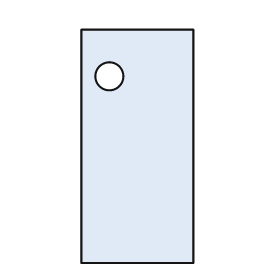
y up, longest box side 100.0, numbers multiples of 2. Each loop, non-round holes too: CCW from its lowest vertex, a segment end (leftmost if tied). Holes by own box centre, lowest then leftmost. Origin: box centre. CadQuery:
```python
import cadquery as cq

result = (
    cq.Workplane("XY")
    .moveTo(-24.0, -50.0)
    .lineTo(24.0, -50.0)
    .lineTo(24.0, 50.0)
    .lineTo(-24.0, 50.0)
    .close()
    .moveTo(-12.0, 30.0)
    .circle(6.0)
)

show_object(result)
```